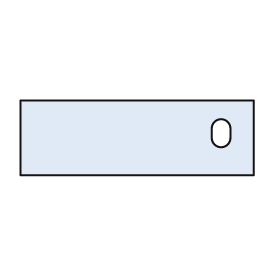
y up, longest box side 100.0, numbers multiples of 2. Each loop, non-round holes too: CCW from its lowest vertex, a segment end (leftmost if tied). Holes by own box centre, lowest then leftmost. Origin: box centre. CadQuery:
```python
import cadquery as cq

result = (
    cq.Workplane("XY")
    .moveTo(-50.0, -16.0)
    .lineTo(50.0, -16.0)
    .lineTo(50.0, 16.0)
    .lineTo(-50.0, 16.0)
    .close()
    .moveTo(32.0, 0.0)
    .threePointArc((36.0, -4.0), (40.0, 0.0))
    .lineTo(40.0, 4.0)
    .threePointArc((36.0, 8.0), (32.0, 4.0))
    .close()
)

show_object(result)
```